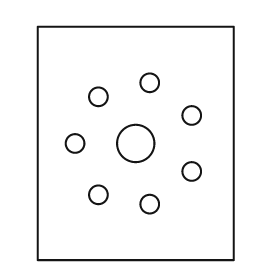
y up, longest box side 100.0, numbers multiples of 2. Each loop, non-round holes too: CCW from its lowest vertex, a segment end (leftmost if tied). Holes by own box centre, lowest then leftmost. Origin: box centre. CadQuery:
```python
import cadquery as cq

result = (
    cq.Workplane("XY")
    .moveTo(-42.0, -50.0)
    .lineTo(42.0, -50.0)
    .lineTo(42.0, 50.0)
    .lineTo(-42.0, 50.0)
    .close()
    .moveTo(6.0, -26.0)
    .circle(4.0)
    .moveTo(-16.0, -22.0)
    .circle(4.0)
    .moveTo(24.0, -12.0)
    .circle(4.0)
    .moveTo(-26.0, 0.0)
    .circle(4.0)
    .moveTo(0.0, 0.0)
    .circle(8.0)
    .moveTo(24.0, 12.0)
    .circle(4.0)
    .moveTo(-16.0, 20.0)
    .circle(4.0)
    .moveTo(6.0, 26.0)
    .circle(4.0)
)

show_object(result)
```